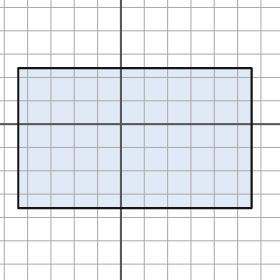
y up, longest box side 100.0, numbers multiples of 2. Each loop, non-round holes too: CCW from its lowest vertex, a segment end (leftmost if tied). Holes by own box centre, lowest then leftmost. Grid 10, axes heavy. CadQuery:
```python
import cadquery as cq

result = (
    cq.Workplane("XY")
    .moveTo(-44.0, -36.0)
    .lineTo(56.0, -36.0)
    .lineTo(56.0, 24.0)
    .lineTo(-44.0, 24.0)
    .close()
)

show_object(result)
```